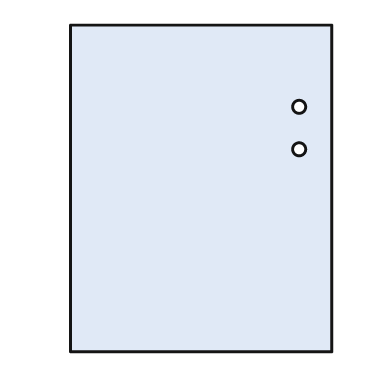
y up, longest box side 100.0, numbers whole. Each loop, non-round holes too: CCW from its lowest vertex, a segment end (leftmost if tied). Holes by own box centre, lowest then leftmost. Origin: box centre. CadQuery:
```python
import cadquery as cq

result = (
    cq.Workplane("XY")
    .moveTo(-40.0, -50.0)
    .lineTo(40.0, -50.0)
    .lineTo(40.0, 50.0)
    .lineTo(-40.0, 50.0)
    .close()
    .moveTo(30.0, 12.0)
    .circle(2.0)
    .moveTo(30.0, 25.0)
    .circle(2.0)
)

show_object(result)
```